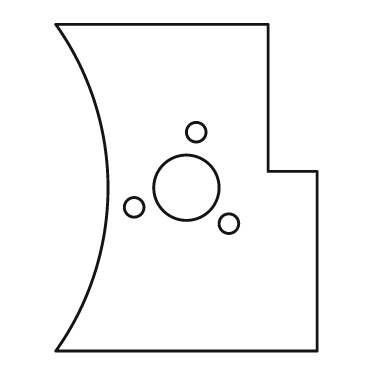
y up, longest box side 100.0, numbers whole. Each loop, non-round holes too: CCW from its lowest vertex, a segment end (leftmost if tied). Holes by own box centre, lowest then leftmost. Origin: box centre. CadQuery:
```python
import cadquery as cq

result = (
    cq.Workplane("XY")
    .moveTo(-40.0, -50.0)
    .lineTo(40.0, -50.0)
    .lineTo(40.0, 5.0)
    .lineTo(25.0, 5.0)
    .lineTo(25.0, 50.0)
    .lineTo(-40.0, 50.0)
    .threePointArc((-24.0, 0.0), (-40.0, -50.0))
    .close()
    .moveTo(13.0, -11.0)
    .circle(3.0)
    .moveTo(-16.0, -6.0)
    .circle(3.0)
    .moveTo(0.0, 0.0)
    .circle(10.0)
    .moveTo(3.0, 17.0)
    .circle(3.0)
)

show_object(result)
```